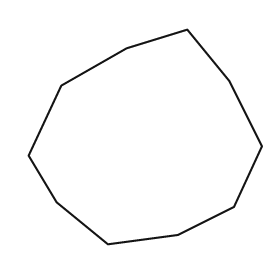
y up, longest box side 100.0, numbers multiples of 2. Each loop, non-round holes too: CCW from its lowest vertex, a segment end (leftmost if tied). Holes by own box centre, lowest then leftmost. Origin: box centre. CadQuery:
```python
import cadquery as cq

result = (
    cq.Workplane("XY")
    .moveTo(-16.0, -46.0)
    .lineTo(14.0, -42.0)
    .lineTo(38.0, -30.0)
    .lineTo(50.0, -4.0)
    .lineTo(36.0, 24.0)
    .lineTo(18.0, 46.0)
    .lineTo(-8.0, 38.0)
    .lineTo(-36.0, 22.0)
    .lineTo(-50.0, -8.0)
    .lineTo(-38.0, -28.0)
    .close()
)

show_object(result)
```